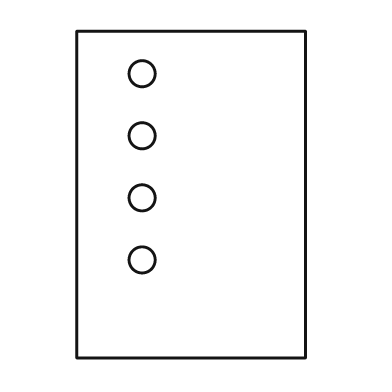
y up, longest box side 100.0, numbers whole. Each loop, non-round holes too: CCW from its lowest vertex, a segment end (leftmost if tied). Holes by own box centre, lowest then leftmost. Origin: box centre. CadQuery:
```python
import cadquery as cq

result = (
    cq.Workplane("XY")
    .moveTo(-35.0, -50.0)
    .lineTo(35.0, -50.0)
    .lineTo(35.0, 50.0)
    .lineTo(-35.0, 50.0)
    .close()
    .moveTo(-15.0, -20.0)
    .circle(4.0)
    .moveTo(-15.0, -1.0)
    .circle(4.0)
    .moveTo(-15.0, 18.0)
    .circle(4.0)
    .moveTo(-15.0, 37.0)
    .circle(4.0)
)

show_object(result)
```